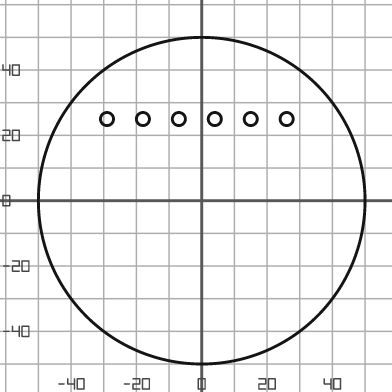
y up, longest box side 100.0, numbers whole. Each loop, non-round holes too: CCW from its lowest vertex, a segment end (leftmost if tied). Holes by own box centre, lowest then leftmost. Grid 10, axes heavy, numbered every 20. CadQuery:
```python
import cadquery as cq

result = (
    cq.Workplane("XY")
    .moveTo(0.0, 0.0)
    .circle(50.0)
    .moveTo(-29.0, 25.0)
    .circle(2.0)
    .moveTo(-18.0, 25.0)
    .circle(2.0)
    .moveTo(-7.0, 25.0)
    .circle(2.0)
    .moveTo(4.0, 25.0)
    .circle(2.0)
    .moveTo(15.0, 25.0)
    .circle(2.0)
    .moveTo(26.0, 25.0)
    .circle(2.0)
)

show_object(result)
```